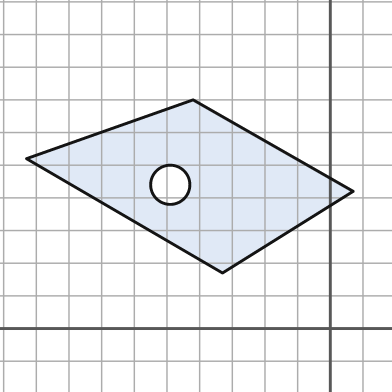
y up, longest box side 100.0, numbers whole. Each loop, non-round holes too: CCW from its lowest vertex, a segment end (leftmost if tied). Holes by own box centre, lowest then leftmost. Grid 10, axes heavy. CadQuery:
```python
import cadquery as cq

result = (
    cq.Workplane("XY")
    .moveTo(-33.0, 17.0)
    .lineTo(7.0, 42.0)
    .lineTo(-42.0, 70.0)
    .lineTo(-93.0, 52.0)
    .close()
    .moveTo(-49.0, 44.0)
    .circle(6.0)
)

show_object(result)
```